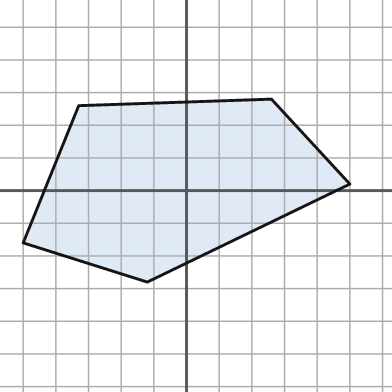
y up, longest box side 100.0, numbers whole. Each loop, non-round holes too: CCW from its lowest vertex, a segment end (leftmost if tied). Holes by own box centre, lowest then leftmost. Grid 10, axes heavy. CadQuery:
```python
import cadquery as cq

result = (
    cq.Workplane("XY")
    .moveTo(-12.0, -28.0)
    .lineTo(50.0, 2.0)
    .lineTo(26.0, 28.0)
    .lineTo(-33.0, 26.0)
    .lineTo(-50.0, -16.0)
    .close()
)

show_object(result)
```